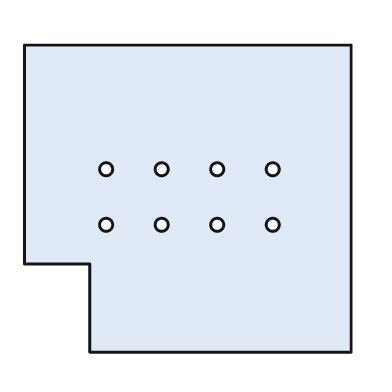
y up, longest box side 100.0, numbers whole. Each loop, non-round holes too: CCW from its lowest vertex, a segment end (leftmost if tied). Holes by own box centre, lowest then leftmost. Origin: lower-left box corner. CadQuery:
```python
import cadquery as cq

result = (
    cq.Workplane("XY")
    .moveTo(20.0, 0.0)
    .lineTo(100.0, 0.0)
    .lineTo(100.0, 94.0)
    .lineTo(0.0, 94.0)
    .lineTo(0.0, 27.0)
    .lineTo(20.0, 27.0)
    .close()
    .moveTo(25.0, 39.0)
    .circle(2.0)
    .moveTo(42.0, 39.0)
    .circle(2.0)
    .moveTo(59.0, 39.0)
    .circle(2.0)
    .moveTo(76.0, 39.0)
    .circle(2.0)
    .moveTo(25.0, 56.0)
    .circle(2.0)
    .moveTo(42.0, 56.0)
    .circle(2.0)
    .moveTo(59.0, 56.0)
    .circle(2.0)
    .moveTo(76.0, 56.0)
    .circle(2.0)
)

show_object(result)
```